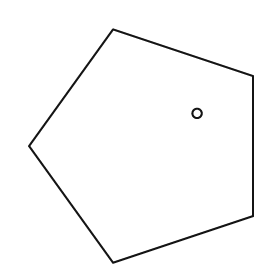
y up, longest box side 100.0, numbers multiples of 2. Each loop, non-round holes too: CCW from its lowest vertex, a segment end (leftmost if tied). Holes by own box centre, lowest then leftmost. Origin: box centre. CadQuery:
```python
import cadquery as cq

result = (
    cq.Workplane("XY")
    .moveTo(-12.0, -50.0)
    .lineTo(48.0, -30.0)
    .lineTo(48.0, 30.0)
    .lineTo(-12.0, 50.0)
    .lineTo(-48.0, 0.0)
    .close()
    .moveTo(24.0, 14.0)
    .circle(2.0)
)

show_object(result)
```